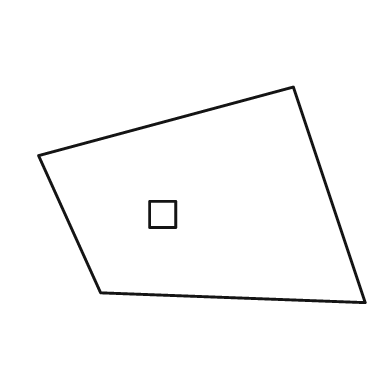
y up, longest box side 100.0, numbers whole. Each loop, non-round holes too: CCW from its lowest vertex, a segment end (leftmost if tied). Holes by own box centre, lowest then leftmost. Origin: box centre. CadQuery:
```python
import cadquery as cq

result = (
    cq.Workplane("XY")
    .moveTo(50.0, -33.0)
    .lineTo(28.0, 33.0)
    .lineTo(-50.0, 12.0)
    .lineTo(-31.0, -30.0)
    .close()
    .moveTo(-16.0, -10.0)
    .lineTo(-8.0, -10.0)
    .lineTo(-8.0, -2.0)
    .lineTo(-16.0, -2.0)
    .close()
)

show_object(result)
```